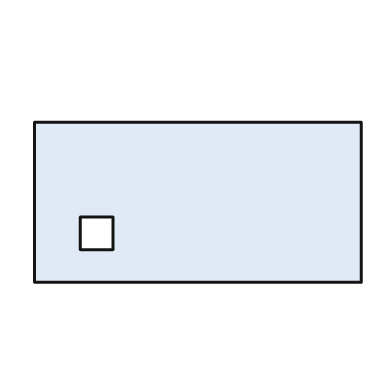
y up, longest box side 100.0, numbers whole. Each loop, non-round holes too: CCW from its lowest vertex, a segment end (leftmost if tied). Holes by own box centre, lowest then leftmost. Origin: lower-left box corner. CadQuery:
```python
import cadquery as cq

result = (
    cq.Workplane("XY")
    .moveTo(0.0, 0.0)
    .lineTo(100.0, 0.0)
    .lineTo(100.0, 49.0)
    .lineTo(0.0, 49.0)
    .close()
    .moveTo(14.0, 10.0)
    .lineTo(24.0, 10.0)
    .lineTo(24.0, 20.0)
    .lineTo(14.0, 20.0)
    .close()
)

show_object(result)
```